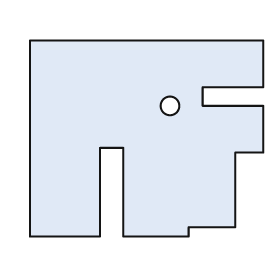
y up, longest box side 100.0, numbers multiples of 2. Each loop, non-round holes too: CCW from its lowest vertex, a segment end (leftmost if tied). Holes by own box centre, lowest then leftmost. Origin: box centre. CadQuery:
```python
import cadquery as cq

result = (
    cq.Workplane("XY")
    .moveTo(-50.0, -42.0)
    .lineTo(-20.0, -42.0)
    .lineTo(-20.0, -4.0)
    .lineTo(-10.0, -4.0)
    .lineTo(-10.0, -42.0)
    .lineTo(18.0, -42.0)
    .lineTo(18.0, -38.0)
    .lineTo(38.0, -38.0)
    .lineTo(38.0, -6.0)
    .lineTo(50.0, -6.0)
    .lineTo(50.0, 14.0)
    .lineTo(24.0, 14.0)
    .lineTo(24.0, 22.0)
    .lineTo(50.0, 22.0)
    .lineTo(50.0, 42.0)
    .lineTo(-50.0, 42.0)
    .close()
    .moveTo(10.0, 14.0)
    .circle(4.0)
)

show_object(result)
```